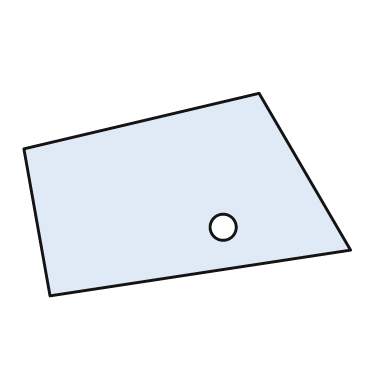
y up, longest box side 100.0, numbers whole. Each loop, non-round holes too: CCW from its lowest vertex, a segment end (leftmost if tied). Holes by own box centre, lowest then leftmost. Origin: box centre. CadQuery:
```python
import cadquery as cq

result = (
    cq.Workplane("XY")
    .moveTo(-42.0, -31.0)
    .lineTo(50.0, -17.0)
    .lineTo(22.0, 31.0)
    .lineTo(-50.0, 14.0)
    .close()
    .moveTo(11.0, -10.0)
    .circle(4.0)
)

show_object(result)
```